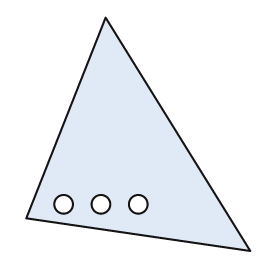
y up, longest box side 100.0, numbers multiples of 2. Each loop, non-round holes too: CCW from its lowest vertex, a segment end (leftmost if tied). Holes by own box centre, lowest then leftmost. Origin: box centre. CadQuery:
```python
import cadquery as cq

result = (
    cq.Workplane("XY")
    .moveTo(48.0, -50.0)
    .lineTo(-14.0, 50.0)
    .lineTo(-48.0, -36.0)
    .close()
    .moveTo(-32.0, -30.0)
    .circle(4.0)
    .moveTo(-16.0, -30.0)
    .circle(4.0)
    .moveTo(0.0, -30.0)
    .circle(4.0)
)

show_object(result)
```